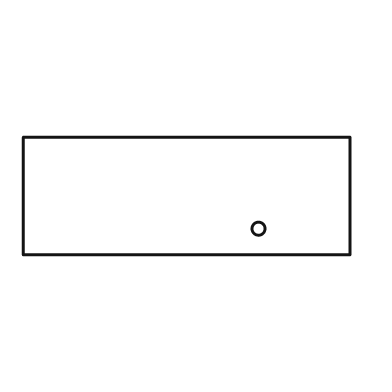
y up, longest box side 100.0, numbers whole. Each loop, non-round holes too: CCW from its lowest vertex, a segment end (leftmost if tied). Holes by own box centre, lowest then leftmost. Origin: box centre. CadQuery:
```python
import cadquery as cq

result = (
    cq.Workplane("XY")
    .moveTo(-50.0, -18.0)
    .lineTo(50.0, -18.0)
    .lineTo(50.0, 18.0)
    .lineTo(-50.0, 18.0)
    .close()
    .moveTo(22.0, -10.0)
    .circle(2.0)
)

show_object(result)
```